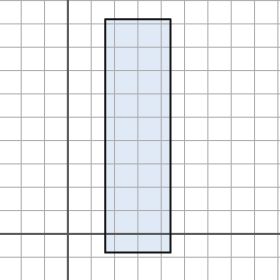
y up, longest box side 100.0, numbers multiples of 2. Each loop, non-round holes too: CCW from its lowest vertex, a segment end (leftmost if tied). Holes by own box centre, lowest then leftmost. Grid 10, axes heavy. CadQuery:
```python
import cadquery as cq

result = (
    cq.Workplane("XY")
    .moveTo(16.0, -8.0)
    .lineTo(44.0, -8.0)
    .lineTo(44.0, 92.0)
    .lineTo(16.0, 92.0)
    .close()
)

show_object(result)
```